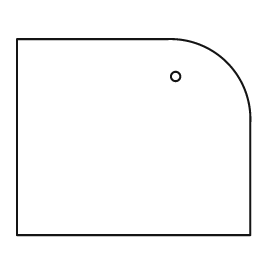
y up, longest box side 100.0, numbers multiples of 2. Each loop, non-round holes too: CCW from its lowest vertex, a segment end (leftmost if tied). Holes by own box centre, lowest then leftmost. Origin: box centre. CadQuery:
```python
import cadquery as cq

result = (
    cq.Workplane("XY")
    .moveTo(-50.0, -42.0)
    .lineTo(50.0, -42.0)
    .lineTo(50.0, 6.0)
    .threePointArc((40.0, 32.0), (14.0, 42.0))
    .lineTo(-50.0, 42.0)
    .close()
    .moveTo(18.0, 26.0)
    .circle(2.0)
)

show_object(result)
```